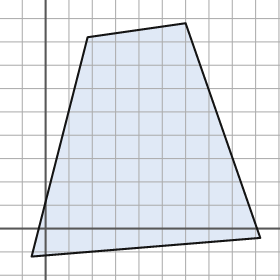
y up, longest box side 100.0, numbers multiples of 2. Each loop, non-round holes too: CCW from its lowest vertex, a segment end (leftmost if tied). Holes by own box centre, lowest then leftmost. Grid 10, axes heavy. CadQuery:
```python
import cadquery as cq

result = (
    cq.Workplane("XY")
    .moveTo(-6.0, -12.0)
    .lineTo(92.0, -4.0)
    .lineTo(60.0, 88.0)
    .lineTo(18.0, 82.0)
    .close()
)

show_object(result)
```